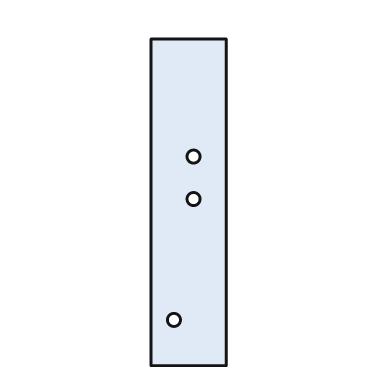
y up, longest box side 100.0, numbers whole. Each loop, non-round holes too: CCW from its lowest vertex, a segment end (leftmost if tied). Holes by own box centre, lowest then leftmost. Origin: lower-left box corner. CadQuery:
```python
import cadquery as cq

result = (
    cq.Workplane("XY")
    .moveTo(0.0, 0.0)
    .lineTo(23.0, 0.0)
    .lineTo(23.0, 100.0)
    .lineTo(0.0, 100.0)
    .close()
    .moveTo(7.0, 14.0)
    .circle(2.0)
    .moveTo(13.0, 51.0)
    .circle(2.0)
    .moveTo(13.0, 64.0)
    .circle(2.0)
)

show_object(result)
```